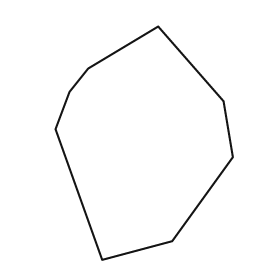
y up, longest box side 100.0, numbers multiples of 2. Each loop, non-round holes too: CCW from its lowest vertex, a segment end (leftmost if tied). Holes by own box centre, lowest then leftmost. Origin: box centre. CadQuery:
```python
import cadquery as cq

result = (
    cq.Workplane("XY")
    .moveTo(-18.0, -50.0)
    .lineTo(12.0, -42.0)
    .lineTo(38.0, -6.0)
    .lineTo(34.0, 18.0)
    .lineTo(6.0, 50.0)
    .lineTo(-24.0, 32.0)
    .lineTo(-32.0, 22.0)
    .lineTo(-38.0, 6.0)
    .close()
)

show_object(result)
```